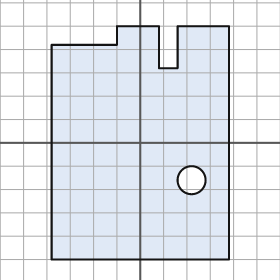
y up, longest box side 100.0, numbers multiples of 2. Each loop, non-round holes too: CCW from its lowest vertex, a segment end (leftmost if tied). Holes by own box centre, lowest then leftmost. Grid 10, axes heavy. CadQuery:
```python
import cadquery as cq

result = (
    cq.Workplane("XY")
    .moveTo(-38.0, -50.0)
    .lineTo(38.0, -50.0)
    .lineTo(38.0, 50.0)
    .lineTo(16.0, 50.0)
    .lineTo(16.0, 32.0)
    .lineTo(8.0, 32.0)
    .lineTo(8.0, 50.0)
    .lineTo(-10.0, 50.0)
    .lineTo(-10.0, 42.0)
    .lineTo(-38.0, 42.0)
    .close()
    .moveTo(22.0, -16.0)
    .circle(6.0)
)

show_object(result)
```